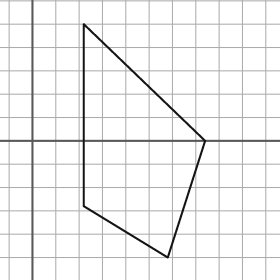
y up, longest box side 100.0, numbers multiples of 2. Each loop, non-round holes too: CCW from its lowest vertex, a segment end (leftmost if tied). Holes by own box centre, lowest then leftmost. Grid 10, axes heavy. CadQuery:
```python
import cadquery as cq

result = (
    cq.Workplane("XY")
    .moveTo(58.0, -50.0)
    .lineTo(74.0, 0.0)
    .lineTo(22.0, 50.0)
    .lineTo(22.0, -28.0)
    .close()
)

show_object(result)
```